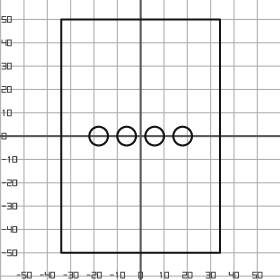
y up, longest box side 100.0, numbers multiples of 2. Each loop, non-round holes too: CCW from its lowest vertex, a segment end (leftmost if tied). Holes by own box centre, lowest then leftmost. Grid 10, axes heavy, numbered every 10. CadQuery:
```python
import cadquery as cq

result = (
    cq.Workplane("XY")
    .moveTo(-34.0, -50.0)
    .lineTo(34.0, -50.0)
    .lineTo(34.0, 50.0)
    .lineTo(-34.0, 50.0)
    .close()
    .moveTo(-18.0, 0.0)
    .circle(4.0)
    .moveTo(-6.0, 0.0)
    .circle(4.0)
    .moveTo(6.0, 0.0)
    .circle(4.0)
    .moveTo(18.0, 0.0)
    .circle(4.0)
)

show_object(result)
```